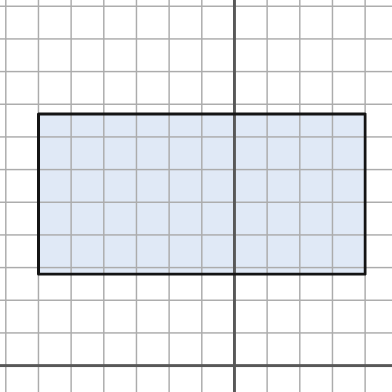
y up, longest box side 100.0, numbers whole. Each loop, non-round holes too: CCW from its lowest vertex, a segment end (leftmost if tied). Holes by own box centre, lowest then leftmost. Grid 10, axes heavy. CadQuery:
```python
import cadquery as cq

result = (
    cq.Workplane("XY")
    .moveTo(-60.0, 28.0)
    .lineTo(40.0, 28.0)
    .lineTo(40.0, 77.0)
    .lineTo(-60.0, 77.0)
    .close()
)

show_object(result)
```